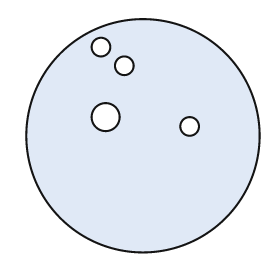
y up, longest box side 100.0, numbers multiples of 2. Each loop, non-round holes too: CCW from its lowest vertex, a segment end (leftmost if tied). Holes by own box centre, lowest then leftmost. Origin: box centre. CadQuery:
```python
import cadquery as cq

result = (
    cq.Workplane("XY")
    .moveTo(0.0, 0.0)
    .circle(50.0)
    .moveTo(20.0, 4.0)
    .circle(4.0)
    .moveTo(-16.0, 8.0)
    .circle(6.0)
    .moveTo(-8.0, 30.0)
    .circle(4.0)
    .moveTo(-18.0, 38.0)
    .circle(4.0)
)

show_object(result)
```